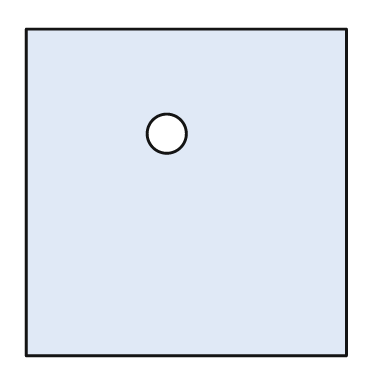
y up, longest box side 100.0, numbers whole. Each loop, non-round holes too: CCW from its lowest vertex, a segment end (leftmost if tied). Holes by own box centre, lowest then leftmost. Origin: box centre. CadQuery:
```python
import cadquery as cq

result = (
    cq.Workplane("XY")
    .moveTo(-49.0, -50.0)
    .lineTo(49.0, -50.0)
    .lineTo(49.0, 50.0)
    .lineTo(-49.0, 50.0)
    .close()
    .moveTo(-6.0, 18.0)
    .circle(6.0)
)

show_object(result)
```